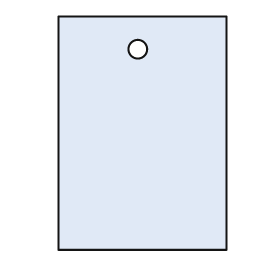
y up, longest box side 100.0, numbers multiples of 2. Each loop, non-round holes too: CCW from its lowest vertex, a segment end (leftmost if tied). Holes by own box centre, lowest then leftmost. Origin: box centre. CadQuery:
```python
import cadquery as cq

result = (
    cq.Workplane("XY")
    .moveTo(-36.0, -50.0)
    .lineTo(36.0, -50.0)
    .lineTo(36.0, 50.0)
    .lineTo(-36.0, 50.0)
    .close()
    .moveTo(-2.0, 36.0)
    .circle(4.0)
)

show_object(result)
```